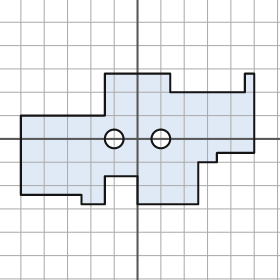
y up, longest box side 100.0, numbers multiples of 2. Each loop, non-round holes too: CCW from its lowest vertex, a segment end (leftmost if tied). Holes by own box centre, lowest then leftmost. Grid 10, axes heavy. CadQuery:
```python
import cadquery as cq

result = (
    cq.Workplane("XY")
    .moveTo(-24.0, -28.0)
    .lineTo(-14.0, -28.0)
    .lineTo(-14.0, -16.0)
    .lineTo(0.0, -16.0)
    .lineTo(0.0, -28.0)
    .lineTo(26.0, -28.0)
    .lineTo(26.0, -10.0)
    .lineTo(34.0, -10.0)
    .lineTo(34.0, -6.0)
    .lineTo(50.0, -6.0)
    .lineTo(50.0, 28.0)
    .lineTo(46.0, 28.0)
    .lineTo(46.0, 20.0)
    .lineTo(14.0, 20.0)
    .lineTo(14.0, 28.0)
    .lineTo(-14.0, 28.0)
    .lineTo(-14.0, 10.0)
    .lineTo(-50.0, 10.0)
    .lineTo(-50.0, -24.0)
    .lineTo(-24.0, -24.0)
    .close()
    .moveTo(-10.0, 0.0)
    .circle(4.0)
    .moveTo(10.0, 0.0)
    .circle(4.0)
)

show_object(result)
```